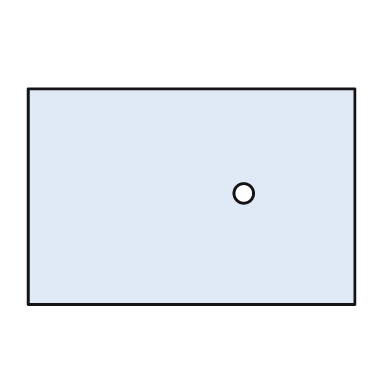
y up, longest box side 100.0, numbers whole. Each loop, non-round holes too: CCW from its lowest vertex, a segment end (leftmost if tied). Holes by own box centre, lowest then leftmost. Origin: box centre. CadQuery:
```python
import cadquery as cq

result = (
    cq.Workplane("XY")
    .moveTo(-50.0, -33.0)
    .lineTo(50.0, -33.0)
    .lineTo(50.0, 33.0)
    .lineTo(-50.0, 33.0)
    .close()
    .moveTo(16.0, 1.0)
    .circle(3.0)
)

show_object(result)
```